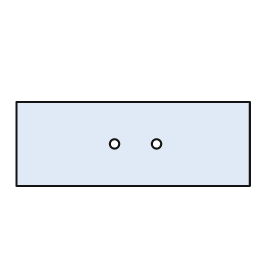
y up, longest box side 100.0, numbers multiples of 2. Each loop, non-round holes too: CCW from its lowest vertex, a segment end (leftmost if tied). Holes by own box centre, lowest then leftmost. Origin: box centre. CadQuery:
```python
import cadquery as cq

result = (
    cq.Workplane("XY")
    .moveTo(-50.0, -18.0)
    .lineTo(50.0, -18.0)
    .lineTo(50.0, 18.0)
    .lineTo(-50.0, 18.0)
    .close()
    .moveTo(-8.0, 0.0)
    .circle(2.0)
    .moveTo(10.0, 0.0)
    .circle(2.0)
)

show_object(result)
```